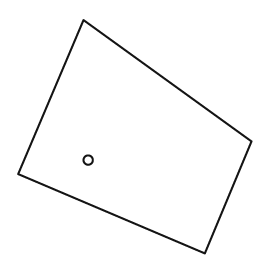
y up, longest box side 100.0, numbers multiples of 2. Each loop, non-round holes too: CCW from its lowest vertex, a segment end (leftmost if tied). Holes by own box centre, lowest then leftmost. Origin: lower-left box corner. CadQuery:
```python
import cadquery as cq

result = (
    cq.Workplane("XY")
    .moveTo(80.0, 0.0)
    .lineTo(100.0, 48.0)
    .lineTo(28.0, 100.0)
    .lineTo(0.0, 34.0)
    .close()
    .moveTo(30.0, 40.0)
    .circle(2.0)
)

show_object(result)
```